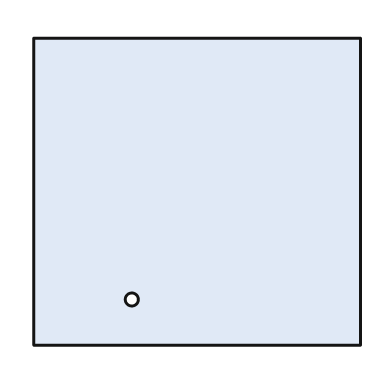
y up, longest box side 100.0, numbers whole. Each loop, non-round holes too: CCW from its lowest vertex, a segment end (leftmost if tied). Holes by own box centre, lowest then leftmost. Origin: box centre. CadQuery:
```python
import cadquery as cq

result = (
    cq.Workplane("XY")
    .moveTo(-50.0, -47.0)
    .lineTo(50.0, -47.0)
    .lineTo(50.0, 47.0)
    .lineTo(-50.0, 47.0)
    .close()
    .moveTo(-20.0, -33.0)
    .circle(2.0)
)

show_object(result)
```